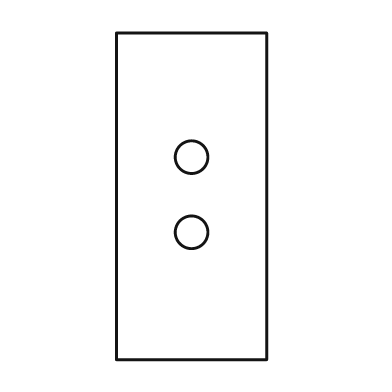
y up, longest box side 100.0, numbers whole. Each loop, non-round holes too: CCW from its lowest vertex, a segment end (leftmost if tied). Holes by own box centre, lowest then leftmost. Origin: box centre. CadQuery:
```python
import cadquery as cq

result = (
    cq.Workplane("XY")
    .moveTo(-23.0, -50.0)
    .lineTo(23.0, -50.0)
    .lineTo(23.0, 50.0)
    .lineTo(-23.0, 50.0)
    .close()
    .moveTo(0.0, -11.0)
    .circle(5.0)
    .moveTo(0.0, 12.0)
    .circle(5.0)
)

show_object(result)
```